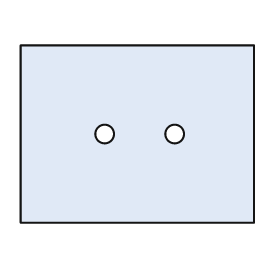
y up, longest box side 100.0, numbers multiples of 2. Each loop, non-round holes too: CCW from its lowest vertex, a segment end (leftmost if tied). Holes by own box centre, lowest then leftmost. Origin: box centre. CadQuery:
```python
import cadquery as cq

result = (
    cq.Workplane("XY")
    .moveTo(-50.0, -38.0)
    .lineTo(50.0, -38.0)
    .lineTo(50.0, 38.0)
    .lineTo(-50.0, 38.0)
    .close()
    .moveTo(-14.0, 0.0)
    .circle(4.0)
    .moveTo(16.0, 0.0)
    .circle(4.0)
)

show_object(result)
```